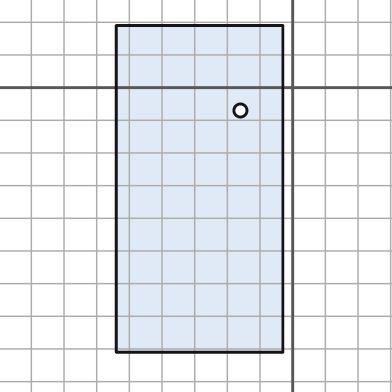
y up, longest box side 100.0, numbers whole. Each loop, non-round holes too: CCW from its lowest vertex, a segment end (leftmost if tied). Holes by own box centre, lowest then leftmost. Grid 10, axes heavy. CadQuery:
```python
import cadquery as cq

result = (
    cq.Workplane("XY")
    .moveTo(-54.0, -81.0)
    .lineTo(-3.0, -81.0)
    .lineTo(-3.0, 19.0)
    .lineTo(-54.0, 19.0)
    .close()
    .moveTo(-16.0, -7.0)
    .circle(2.0)
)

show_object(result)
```